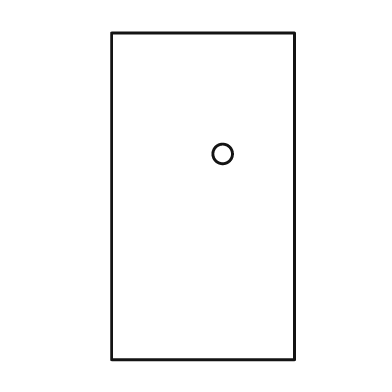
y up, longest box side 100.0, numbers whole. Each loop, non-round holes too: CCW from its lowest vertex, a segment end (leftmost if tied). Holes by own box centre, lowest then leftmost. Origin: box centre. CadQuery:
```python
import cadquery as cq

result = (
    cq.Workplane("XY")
    .moveTo(-28.0, -50.0)
    .lineTo(28.0, -50.0)
    .lineTo(28.0, 50.0)
    .lineTo(-28.0, 50.0)
    .close()
    .moveTo(6.0, 13.0)
    .circle(3.0)
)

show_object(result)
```